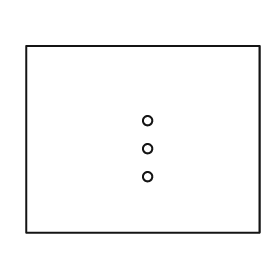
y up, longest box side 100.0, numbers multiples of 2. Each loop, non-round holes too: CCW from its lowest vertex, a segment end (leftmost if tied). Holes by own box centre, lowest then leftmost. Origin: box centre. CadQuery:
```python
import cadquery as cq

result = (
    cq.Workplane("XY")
    .moveTo(-50.0, -40.0)
    .lineTo(50.0, -40.0)
    .lineTo(50.0, 40.0)
    .lineTo(-50.0, 40.0)
    .close()
    .moveTo(2.0, -16.0)
    .circle(2.0)
    .moveTo(2.0, -4.0)
    .circle(2.0)
    .moveTo(2.0, 8.0)
    .circle(2.0)
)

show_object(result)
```